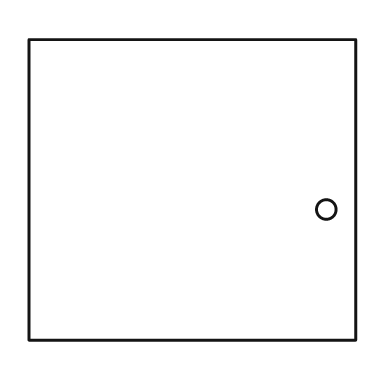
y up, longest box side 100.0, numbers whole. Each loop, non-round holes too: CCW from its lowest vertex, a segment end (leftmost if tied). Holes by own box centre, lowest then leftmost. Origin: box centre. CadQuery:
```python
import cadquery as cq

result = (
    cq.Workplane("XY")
    .moveTo(-50.0, -46.0)
    .lineTo(50.0, -46.0)
    .lineTo(50.0, 46.0)
    .lineTo(-50.0, 46.0)
    .close()
    .moveTo(41.0, -6.0)
    .circle(3.0)
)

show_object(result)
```